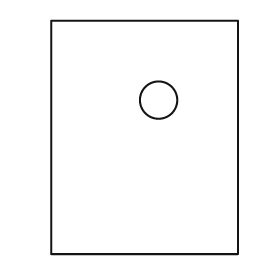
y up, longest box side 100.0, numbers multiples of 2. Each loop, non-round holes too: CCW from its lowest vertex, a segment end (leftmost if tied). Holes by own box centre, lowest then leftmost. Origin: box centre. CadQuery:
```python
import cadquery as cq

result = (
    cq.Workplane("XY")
    .moveTo(-40.0, -50.0)
    .lineTo(40.0, -50.0)
    .lineTo(40.0, 50.0)
    .lineTo(-40.0, 50.0)
    .close()
    .moveTo(6.0, 16.0)
    .circle(8.0)
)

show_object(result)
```